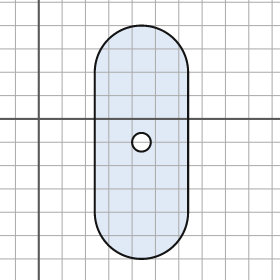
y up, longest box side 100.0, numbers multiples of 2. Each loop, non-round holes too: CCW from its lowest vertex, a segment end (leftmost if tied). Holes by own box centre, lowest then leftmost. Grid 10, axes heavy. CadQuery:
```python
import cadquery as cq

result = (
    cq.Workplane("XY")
    .moveTo(24.0, -40.0)
    .threePointArc((44.0, -60.0), (64.0, -40.0))
    .lineTo(64.0, 20.0)
    .threePointArc((44.0, 40.0), (24.0, 20.0))
    .close()
    .moveTo(44.0, -10.0)
    .circle(4.0)
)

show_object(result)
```